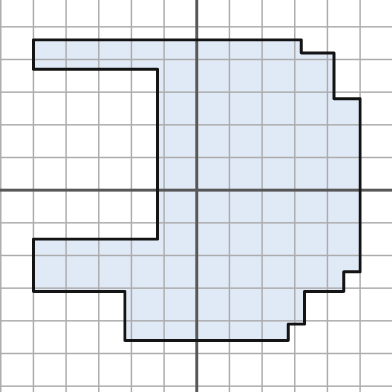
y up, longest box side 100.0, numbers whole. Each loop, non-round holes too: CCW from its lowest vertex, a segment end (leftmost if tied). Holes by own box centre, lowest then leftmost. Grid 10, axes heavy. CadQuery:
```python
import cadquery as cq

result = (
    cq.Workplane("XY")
    .moveTo(-22.0, -46.0)
    .lineTo(28.0, -46.0)
    .lineTo(28.0, -41.0)
    .lineTo(33.0, -41.0)
    .lineTo(33.0, -31.0)
    .lineTo(45.0, -31.0)
    .lineTo(45.0, -25.0)
    .lineTo(50.0, -25.0)
    .lineTo(50.0, 28.0)
    .lineTo(42.0, 28.0)
    .lineTo(42.0, 42.0)
    .lineTo(32.0, 42.0)
    .lineTo(32.0, 46.0)
    .lineTo(-50.0, 46.0)
    .lineTo(-50.0, 37.0)
    .lineTo(-12.0, 37.0)
    .lineTo(-12.0, -15.0)
    .lineTo(-50.0, -15.0)
    .lineTo(-50.0, -31.0)
    .lineTo(-22.0, -31.0)
    .close()
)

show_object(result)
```